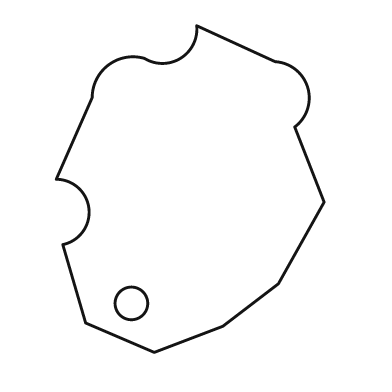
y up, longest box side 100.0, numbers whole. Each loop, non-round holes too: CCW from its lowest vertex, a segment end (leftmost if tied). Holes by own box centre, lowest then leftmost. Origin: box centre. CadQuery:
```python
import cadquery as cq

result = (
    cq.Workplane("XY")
    .moveTo(-11.0, -50.0)
    .lineTo(10.0, -42.0)
    .lineTo(27.0, -29.0)
    .lineTo(41.0, -4.0)
    .lineTo(32.0, 19.0)
    .threePointArc((36.0, 31.0), (26.0, 39.0))
    .lineTo(2.0, 50.0)
    .threePointArc((-3.0, 40.0), (-14.0, 40.0))
    .threePointArc((-25.0, 38.0), (-30.0, 28.0))
    .lineTo(-41.0, 3.0)
    .threePointArc((-31.0, -6.0), (-39.0, -17.0))
    .lineTo(-32.0, -41.0)
    .close()
    .moveTo(-18.0, -35.0)
    .circle(5.0)
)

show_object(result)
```